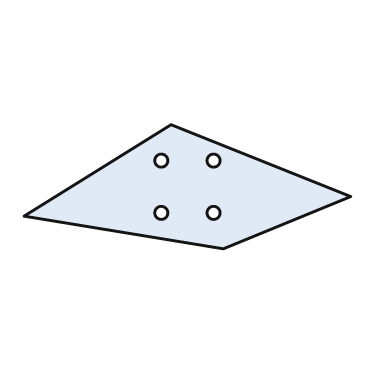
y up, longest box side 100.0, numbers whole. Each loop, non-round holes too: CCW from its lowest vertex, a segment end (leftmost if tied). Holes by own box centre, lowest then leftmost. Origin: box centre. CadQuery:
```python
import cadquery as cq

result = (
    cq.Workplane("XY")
    .moveTo(11.0, -19.0)
    .lineTo(50.0, -3.0)
    .lineTo(-5.0, 19.0)
    .lineTo(-50.0, -9.0)
    .close()
    .moveTo(-8.0, -8.0)
    .circle(2.0)
    .moveTo(8.0, -8.0)
    .circle(2.0)
    .moveTo(-8.0, 8.0)
    .circle(2.0)
    .moveTo(8.0, 8.0)
    .circle(2.0)
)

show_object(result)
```